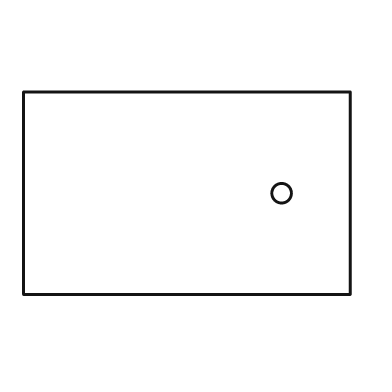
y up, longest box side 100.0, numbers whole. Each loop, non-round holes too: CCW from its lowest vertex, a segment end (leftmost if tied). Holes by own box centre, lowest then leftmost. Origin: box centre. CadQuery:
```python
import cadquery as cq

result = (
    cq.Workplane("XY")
    .moveTo(-50.0, -31.0)
    .lineTo(50.0, -31.0)
    .lineTo(50.0, 31.0)
    .lineTo(-50.0, 31.0)
    .close()
    .moveTo(29.0, 0.0)
    .circle(3.0)
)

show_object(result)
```